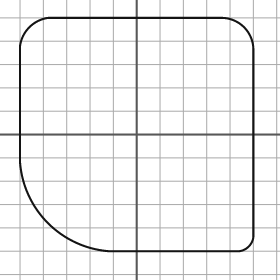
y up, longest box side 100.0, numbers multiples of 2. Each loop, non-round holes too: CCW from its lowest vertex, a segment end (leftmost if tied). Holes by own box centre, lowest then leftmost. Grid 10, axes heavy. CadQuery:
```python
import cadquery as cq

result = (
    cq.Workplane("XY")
    .moveTo(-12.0, -50.0)
    .lineTo(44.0, -50.0)
    .threePointArc((48.0, -48.0), (50.0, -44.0))
    .lineTo(50.0, 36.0)
    .threePointArc((46.0, 46.0), (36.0, 50.0))
    .lineTo(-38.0, 50.0)
    .threePointArc((-46.0, 46.0), (-50.0, 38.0))
    .lineTo(-50.0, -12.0)
    .threePointArc((-38.0, -38.0), (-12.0, -50.0))
    .close()
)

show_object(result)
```